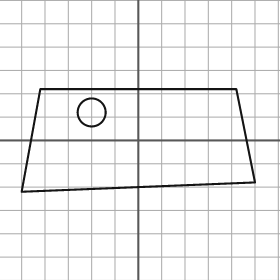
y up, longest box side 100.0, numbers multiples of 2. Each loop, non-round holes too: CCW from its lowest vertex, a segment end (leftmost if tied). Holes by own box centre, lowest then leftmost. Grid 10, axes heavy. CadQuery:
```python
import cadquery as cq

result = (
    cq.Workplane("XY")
    .moveTo(-50.0, -22.0)
    .lineTo(50.0, -18.0)
    .lineTo(42.0, 22.0)
    .lineTo(-42.0, 22.0)
    .close()
    .moveTo(-20.0, 12.0)
    .circle(6.0)
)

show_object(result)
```